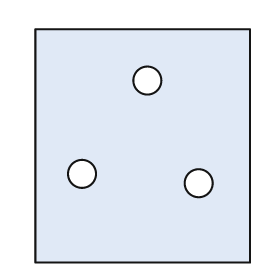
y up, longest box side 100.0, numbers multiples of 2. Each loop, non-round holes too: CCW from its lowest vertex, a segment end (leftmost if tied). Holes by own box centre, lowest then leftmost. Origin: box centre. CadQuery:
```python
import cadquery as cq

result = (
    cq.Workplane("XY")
    .moveTo(-46.0, -50.0)
    .lineTo(46.0, -50.0)
    .lineTo(46.0, 50.0)
    .lineTo(-46.0, 50.0)
    .close()
    .moveTo(24.0, -16.0)
    .circle(6.0)
    .moveTo(-26.0, -12.0)
    .circle(6.0)
    .moveTo(2.0, 28.0)
    .circle(6.0)
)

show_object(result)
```